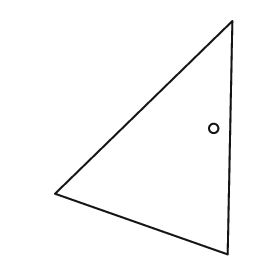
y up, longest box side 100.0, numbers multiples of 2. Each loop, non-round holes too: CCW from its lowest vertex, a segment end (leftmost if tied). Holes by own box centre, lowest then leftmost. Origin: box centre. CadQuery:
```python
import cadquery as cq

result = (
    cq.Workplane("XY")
    .moveTo(36.0, -50.0)
    .lineTo(38.0, 50.0)
    .lineTo(-38.0, -24.0)
    .close()
    .moveTo(30.0, 4.0)
    .circle(2.0)
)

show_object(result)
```